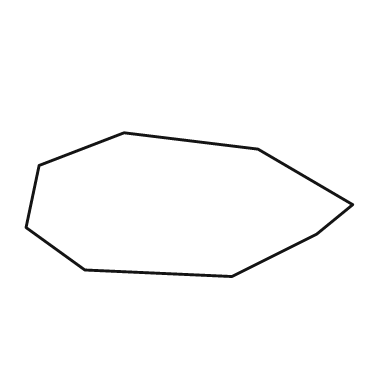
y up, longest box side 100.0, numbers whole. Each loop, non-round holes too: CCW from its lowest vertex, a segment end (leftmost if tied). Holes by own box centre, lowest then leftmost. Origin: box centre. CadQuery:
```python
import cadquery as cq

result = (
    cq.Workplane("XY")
    .moveTo(13.0, -22.0)
    .lineTo(39.0, -9.0)
    .lineTo(50.0, 0.0)
    .lineTo(21.0, 17.0)
    .lineTo(-20.0, 22.0)
    .lineTo(-46.0, 12.0)
    .lineTo(-50.0, -7.0)
    .lineTo(-32.0, -20.0)
    .close()
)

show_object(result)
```